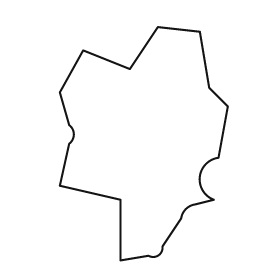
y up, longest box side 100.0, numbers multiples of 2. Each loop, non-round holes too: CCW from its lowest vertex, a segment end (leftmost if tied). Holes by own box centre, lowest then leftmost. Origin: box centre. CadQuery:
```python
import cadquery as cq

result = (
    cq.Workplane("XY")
    .moveTo(-10.0, -50.0)
    .lineTo(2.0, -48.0)
    .threePointArc((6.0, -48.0), (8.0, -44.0))
    .lineTo(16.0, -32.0)
    .threePointArc((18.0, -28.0), (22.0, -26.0))
    .lineTo(30.0, -24.0)
    .threePointArc((24.0, -14.0), (32.0, -6.0))
    .lineTo(36.0, 16.0)
    .lineTo(28.0, 24.0)
    .lineTo(24.0, 48.0)
    .lineTo(6.0, 50.0)
    .lineTo(-6.0, 32.0)
    .lineTo(-26.0, 40.0)
    .lineTo(-36.0, 22.0)
    .lineTo(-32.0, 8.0)
    .threePointArc((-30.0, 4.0), (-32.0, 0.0))
    .lineTo(-36.0, -18.0)
    .lineTo(-10.0, -24.0)
    .close()
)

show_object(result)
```